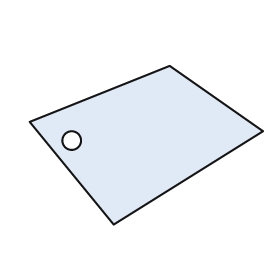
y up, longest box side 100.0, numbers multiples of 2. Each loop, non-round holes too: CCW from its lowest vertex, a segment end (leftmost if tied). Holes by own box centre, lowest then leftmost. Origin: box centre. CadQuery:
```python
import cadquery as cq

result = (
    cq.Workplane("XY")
    .moveTo(-14.0, -34.0)
    .lineTo(50.0, 6.0)
    .lineTo(10.0, 34.0)
    .lineTo(-50.0, 10.0)
    .close()
    .moveTo(-32.0, 2.0)
    .circle(4.0)
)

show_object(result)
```